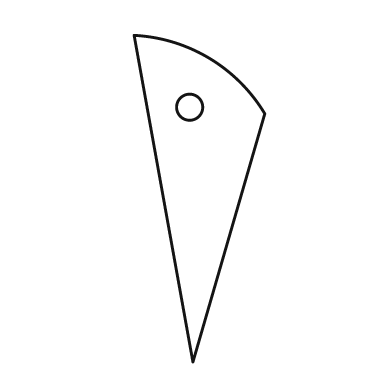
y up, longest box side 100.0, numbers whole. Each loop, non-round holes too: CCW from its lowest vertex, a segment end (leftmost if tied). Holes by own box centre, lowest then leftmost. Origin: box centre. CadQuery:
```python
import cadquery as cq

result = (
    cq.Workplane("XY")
    .moveTo(-2.0, -50.0)
    .lineTo(20.0, 26.0)
    .threePointArc((3.0, 43.0), (-20.0, 50.0))
    .close()
    .moveTo(-3.0, 28.0)
    .circle(4.0)
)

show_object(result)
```